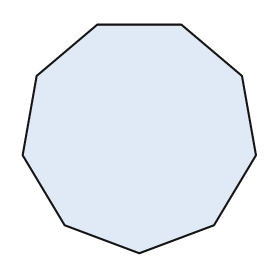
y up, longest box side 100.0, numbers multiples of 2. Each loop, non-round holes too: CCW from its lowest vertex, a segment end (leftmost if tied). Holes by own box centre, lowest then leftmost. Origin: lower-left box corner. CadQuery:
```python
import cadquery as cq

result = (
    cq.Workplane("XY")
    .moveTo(50.0, 0.0)
    .lineTo(82.0, 12.0)
    .lineTo(100.0, 42.0)
    .lineTo(94.0, 76.0)
    .lineTo(68.0, 98.0)
    .lineTo(32.0, 98.0)
    .lineTo(6.0, 76.0)
    .lineTo(0.0, 42.0)
    .lineTo(18.0, 12.0)
    .close()
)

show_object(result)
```